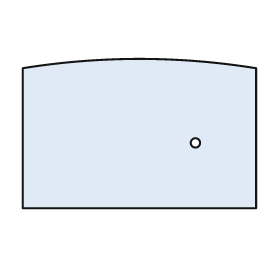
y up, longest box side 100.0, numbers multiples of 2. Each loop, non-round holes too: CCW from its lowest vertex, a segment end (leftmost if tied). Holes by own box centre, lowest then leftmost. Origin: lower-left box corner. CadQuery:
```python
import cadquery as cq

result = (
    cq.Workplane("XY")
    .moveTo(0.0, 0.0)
    .lineTo(100.0, 0.0)
    .lineTo(100.0, 60.0)
    .threePointArc((50.0, 64.0), (0.0, 60.0))
    .close()
    .moveTo(74.0, 28.0)
    .circle(2.0)
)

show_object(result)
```